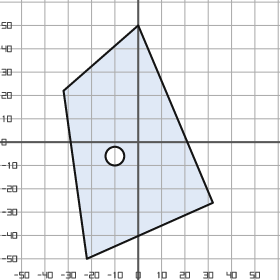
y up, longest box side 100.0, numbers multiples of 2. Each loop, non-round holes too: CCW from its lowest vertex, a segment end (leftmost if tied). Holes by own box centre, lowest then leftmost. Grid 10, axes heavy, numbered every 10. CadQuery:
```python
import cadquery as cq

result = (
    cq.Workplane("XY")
    .moveTo(-22.0, -50.0)
    .lineTo(32.0, -26.0)
    .lineTo(0.0, 50.0)
    .lineTo(-32.0, 22.0)
    .close()
    .moveTo(-10.0, -6.0)
    .circle(4.0)
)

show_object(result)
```